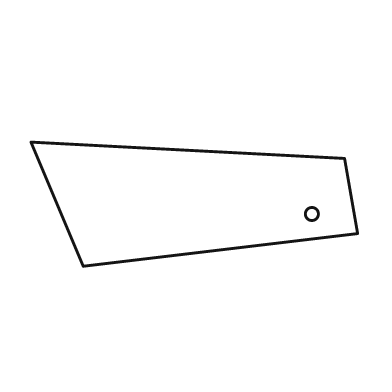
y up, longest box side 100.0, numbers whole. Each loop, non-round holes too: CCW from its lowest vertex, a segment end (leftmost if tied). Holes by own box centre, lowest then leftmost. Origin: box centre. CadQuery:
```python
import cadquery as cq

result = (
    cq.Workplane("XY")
    .moveTo(-34.0, -19.0)
    .lineTo(50.0, -9.0)
    .lineTo(46.0, 14.0)
    .lineTo(-50.0, 19.0)
    .close()
    .moveTo(36.0, -3.0)
    .circle(2.0)
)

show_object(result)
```